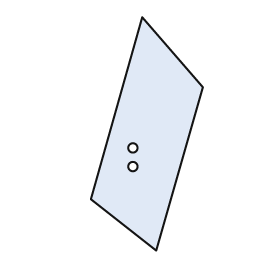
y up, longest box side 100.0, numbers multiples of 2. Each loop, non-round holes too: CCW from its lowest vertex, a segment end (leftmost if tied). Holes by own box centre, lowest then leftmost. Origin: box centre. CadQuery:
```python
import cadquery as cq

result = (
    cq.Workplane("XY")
    .moveTo(4.0, -50.0)
    .lineTo(24.0, 20.0)
    .lineTo(-2.0, 50.0)
    .lineTo(-24.0, -28.0)
    .close()
    .moveTo(-6.0, -14.0)
    .circle(2.0)
    .moveTo(-6.0, -6.0)
    .circle(2.0)
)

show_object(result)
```